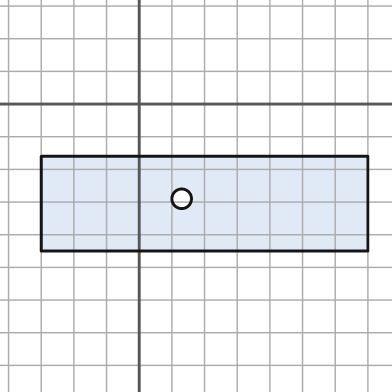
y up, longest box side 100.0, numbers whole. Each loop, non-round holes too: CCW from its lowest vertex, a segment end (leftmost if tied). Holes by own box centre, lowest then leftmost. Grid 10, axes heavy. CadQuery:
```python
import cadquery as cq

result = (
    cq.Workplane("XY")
    .moveTo(-30.0, -45.0)
    .lineTo(70.0, -45.0)
    .lineTo(70.0, -16.0)
    .lineTo(-30.0, -16.0)
    .close()
    .moveTo(13.0, -29.0)
    .circle(3.0)
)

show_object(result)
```